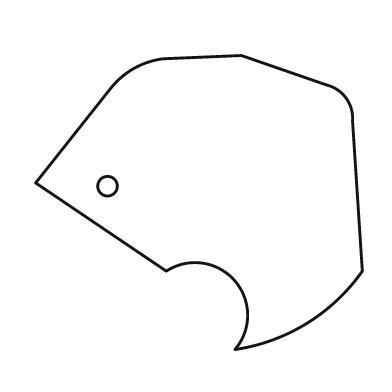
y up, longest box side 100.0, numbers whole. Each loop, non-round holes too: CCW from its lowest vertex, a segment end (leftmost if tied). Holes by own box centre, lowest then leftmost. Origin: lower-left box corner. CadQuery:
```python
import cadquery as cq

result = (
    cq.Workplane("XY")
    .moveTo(61.0, 0.0)
    .threePointArc((83.0, 8.0), (100.0, 24.0))
    .lineTo(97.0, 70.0)
    .threePointArc((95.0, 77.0), (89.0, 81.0))
    .lineTo(63.0, 90.0)
    .lineTo(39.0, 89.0)
    .threePointArc((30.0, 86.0), (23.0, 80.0))
    .lineTo(0.0, 51.0)
    .lineTo(40.0, 24.0)
    .threePointArc((61.0, 21.0), (61.0, 0.0))
    .close()
    .moveTo(22.0, 50.0)
    .circle(3.0)
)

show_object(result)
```